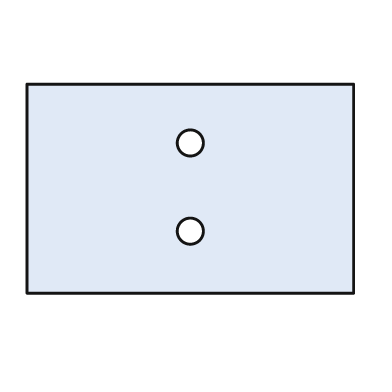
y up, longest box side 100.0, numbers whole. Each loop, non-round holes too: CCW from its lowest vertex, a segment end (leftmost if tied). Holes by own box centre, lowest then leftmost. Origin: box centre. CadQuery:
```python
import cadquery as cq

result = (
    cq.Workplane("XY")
    .moveTo(-50.0, -32.0)
    .lineTo(50.0, -32.0)
    .lineTo(50.0, 32.0)
    .lineTo(-50.0, 32.0)
    .close()
    .moveTo(0.0, -13.0)
    .circle(4.0)
    .moveTo(0.0, 14.0)
    .circle(4.0)
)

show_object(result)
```